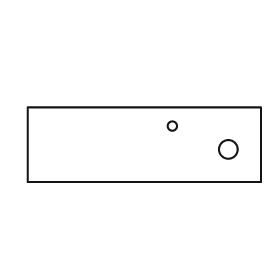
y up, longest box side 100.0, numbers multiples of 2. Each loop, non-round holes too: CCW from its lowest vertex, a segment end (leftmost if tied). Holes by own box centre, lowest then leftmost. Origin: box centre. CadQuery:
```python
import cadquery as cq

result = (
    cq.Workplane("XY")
    .moveTo(-50.0, -16.0)
    .lineTo(50.0, -16.0)
    .lineTo(50.0, 16.0)
    .lineTo(-50.0, 16.0)
    .close()
    .moveTo(36.0, -2.0)
    .circle(4.0)
    .moveTo(12.0, 8.0)
    .circle(2.0)
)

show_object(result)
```